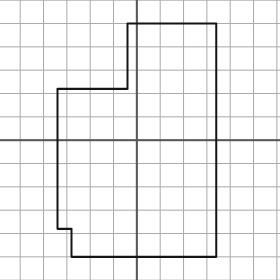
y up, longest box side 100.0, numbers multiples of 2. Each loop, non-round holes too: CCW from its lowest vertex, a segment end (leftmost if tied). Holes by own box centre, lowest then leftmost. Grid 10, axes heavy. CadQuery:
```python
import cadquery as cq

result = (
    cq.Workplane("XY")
    .moveTo(-28.0, -50.0)
    .lineTo(34.0, -50.0)
    .lineTo(34.0, 50.0)
    .lineTo(-4.0, 50.0)
    .lineTo(-4.0, 22.0)
    .lineTo(-34.0, 22.0)
    .lineTo(-34.0, -38.0)
    .lineTo(-28.0, -38.0)
    .close()
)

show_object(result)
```